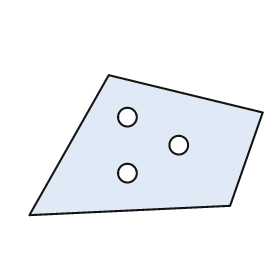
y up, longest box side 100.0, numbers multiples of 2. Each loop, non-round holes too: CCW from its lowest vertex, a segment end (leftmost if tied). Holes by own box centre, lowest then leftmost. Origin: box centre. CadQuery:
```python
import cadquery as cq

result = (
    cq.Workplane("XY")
    .moveTo(-50.0, -30.0)
    .lineTo(36.0, -26.0)
    .lineTo(50.0, 14.0)
    .lineTo(-16.0, 30.0)
    .close()
    .moveTo(-8.0, -12.0)
    .circle(4.0)
    .moveTo(14.0, 0.0)
    .circle(4.0)
    .moveTo(-8.0, 12.0)
    .circle(4.0)
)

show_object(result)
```